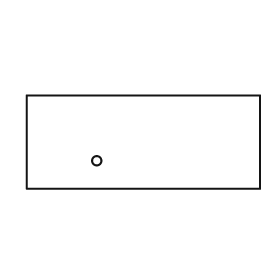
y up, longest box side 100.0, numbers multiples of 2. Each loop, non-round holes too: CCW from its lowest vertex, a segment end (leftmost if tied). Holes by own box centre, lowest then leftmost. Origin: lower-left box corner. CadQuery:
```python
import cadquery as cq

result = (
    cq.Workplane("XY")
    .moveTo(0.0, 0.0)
    .lineTo(100.0, 0.0)
    .lineTo(100.0, 40.0)
    .lineTo(0.0, 40.0)
    .close()
    .moveTo(30.0, 12.0)
    .circle(2.0)
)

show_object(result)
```